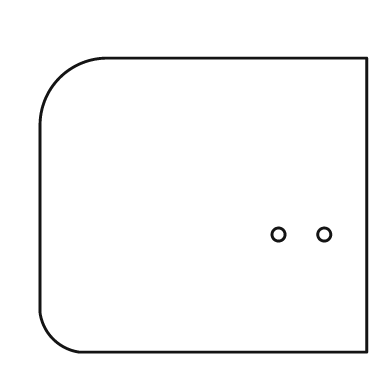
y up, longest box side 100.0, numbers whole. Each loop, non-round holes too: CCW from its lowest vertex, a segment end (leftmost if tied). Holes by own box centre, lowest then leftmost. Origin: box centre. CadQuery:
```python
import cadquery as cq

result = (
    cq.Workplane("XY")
    .moveTo(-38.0, -45.0)
    .lineTo(50.0, -45.0)
    .lineTo(50.0, 45.0)
    .lineTo(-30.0, 45.0)
    .threePointArc((-44.0, 39.0), (-50.0, 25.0))
    .lineTo(-50.0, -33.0)
    .threePointArc((-46.0, -41.0), (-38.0, -45.0))
    .close()
    .moveTo(23.0, -9.0)
    .circle(2.0)
    .moveTo(37.0, -9.0)
    .circle(2.0)
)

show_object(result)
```